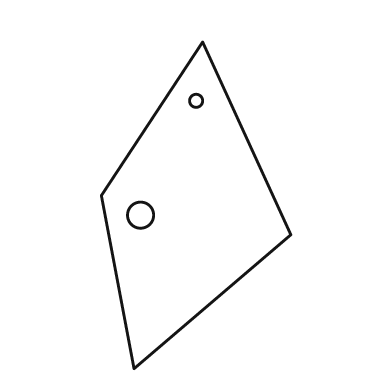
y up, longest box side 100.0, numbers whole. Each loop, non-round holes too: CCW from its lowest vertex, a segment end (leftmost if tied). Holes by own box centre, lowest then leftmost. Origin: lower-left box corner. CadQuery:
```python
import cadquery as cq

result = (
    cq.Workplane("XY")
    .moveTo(10.0, 0.0)
    .lineTo(58.0, 41.0)
    .lineTo(31.0, 100.0)
    .lineTo(0.0, 53.0)
    .close()
    .moveTo(12.0, 47.0)
    .circle(4.0)
    .moveTo(29.0, 82.0)
    .circle(2.0)
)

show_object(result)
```